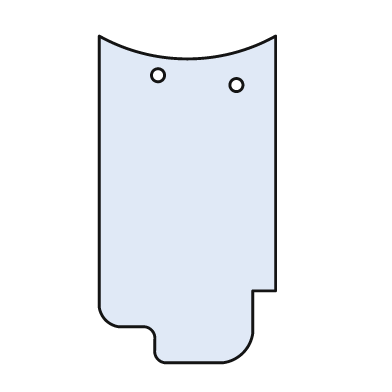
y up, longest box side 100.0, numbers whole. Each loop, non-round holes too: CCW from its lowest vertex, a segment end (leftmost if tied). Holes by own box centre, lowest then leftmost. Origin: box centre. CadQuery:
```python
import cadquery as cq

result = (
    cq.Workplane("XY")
    .moveTo(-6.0, -50.0)
    .lineTo(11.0, -50.0)
    .threePointArc((17.0, -47.0), (20.0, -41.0))
    .lineTo(20.0, -28.0)
    .lineTo(27.0, -28.0)
    .lineTo(27.0, 50.0)
    .threePointArc((0.0, 43.0), (-27.0, 50.0))
    .lineTo(-27.0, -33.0)
    .threePointArc((-25.0, -37.0), (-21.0, -39.0))
    .lineTo(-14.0, -39.0)
    .threePointArc((-11.0, -40.0), (-10.0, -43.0))
    .lineTo(-10.0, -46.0)
    .threePointArc((-9.0, -49.0), (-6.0, -50.0))
    .close()
    .moveTo(15.0, 35.0)
    .circle(2.0)
    .moveTo(-9.0, 38.0)
    .circle(2.0)
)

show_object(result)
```